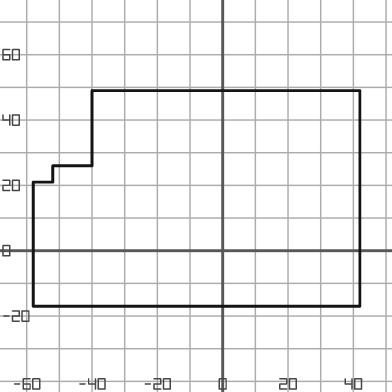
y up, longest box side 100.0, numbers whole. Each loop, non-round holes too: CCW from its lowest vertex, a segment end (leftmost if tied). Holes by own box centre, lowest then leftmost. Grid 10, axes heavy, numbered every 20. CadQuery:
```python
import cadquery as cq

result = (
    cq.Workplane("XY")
    .moveTo(-58.0, -17.0)
    .lineTo(42.0, -17.0)
    .lineTo(42.0, 49.0)
    .lineTo(-40.0, 49.0)
    .lineTo(-40.0, 26.0)
    .lineTo(-52.0, 26.0)
    .lineTo(-52.0, 21.0)
    .lineTo(-58.0, 21.0)
    .close()
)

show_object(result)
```